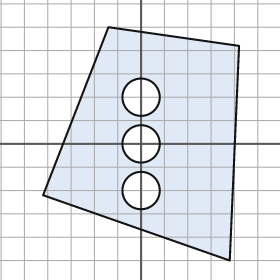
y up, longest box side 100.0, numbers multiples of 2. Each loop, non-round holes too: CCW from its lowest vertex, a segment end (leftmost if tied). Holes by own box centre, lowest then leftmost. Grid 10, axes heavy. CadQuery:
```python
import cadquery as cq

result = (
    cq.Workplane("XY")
    .moveTo(38.0, -50.0)
    .lineTo(42.0, 42.0)
    .lineTo(-14.0, 50.0)
    .lineTo(-42.0, -22.0)
    .close()
    .moveTo(0.0, -20.0)
    .circle(8.0)
    .moveTo(0.0, 0.0)
    .circle(8.0)
    .moveTo(0.0, 20.0)
    .circle(8.0)
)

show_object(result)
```